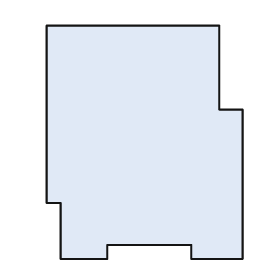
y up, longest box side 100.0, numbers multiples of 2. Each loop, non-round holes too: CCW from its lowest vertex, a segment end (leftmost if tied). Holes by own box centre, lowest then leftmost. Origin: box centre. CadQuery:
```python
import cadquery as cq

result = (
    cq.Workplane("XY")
    .moveTo(-36.0, -50.0)
    .lineTo(-16.0, -50.0)
    .lineTo(-16.0, -44.0)
    .lineTo(20.0, -44.0)
    .lineTo(20.0, -50.0)
    .lineTo(42.0, -50.0)
    .lineTo(42.0, 14.0)
    .lineTo(32.0, 14.0)
    .lineTo(32.0, 50.0)
    .lineTo(-42.0, 50.0)
    .lineTo(-42.0, -26.0)
    .lineTo(-36.0, -26.0)
    .close()
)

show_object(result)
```